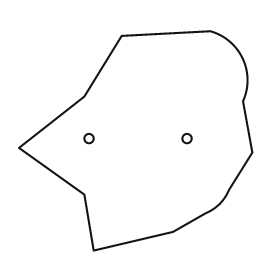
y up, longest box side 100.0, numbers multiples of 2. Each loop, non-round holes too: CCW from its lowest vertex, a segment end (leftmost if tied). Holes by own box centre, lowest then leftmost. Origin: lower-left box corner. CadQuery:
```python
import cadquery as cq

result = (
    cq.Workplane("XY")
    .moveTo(32.0, 0.0)
    .lineTo(66.0, 8.0)
    .lineTo(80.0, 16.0)
    .threePointArc((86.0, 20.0), (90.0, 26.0))
    .lineTo(100.0, 42.0)
    .lineTo(96.0, 64.0)
    .threePointArc((96.0, 82.0), (82.0, 94.0))
    .lineTo(44.0, 92.0)
    .lineTo(28.0, 66.0)
    .lineTo(0.0, 44.0)
    .lineTo(28.0, 24.0)
    .close()
    .moveTo(30.0, 48.0)
    .circle(2.0)
    .moveTo(72.0, 48.0)
    .circle(2.0)
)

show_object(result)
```